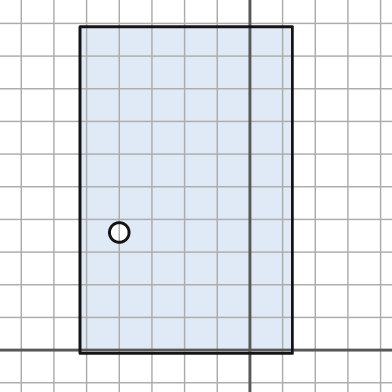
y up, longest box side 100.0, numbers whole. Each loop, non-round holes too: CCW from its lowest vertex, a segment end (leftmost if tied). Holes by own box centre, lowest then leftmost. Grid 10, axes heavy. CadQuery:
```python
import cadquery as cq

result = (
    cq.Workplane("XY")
    .moveTo(-52.0, -1.0)
    .lineTo(13.0, -1.0)
    .lineTo(13.0, 99.0)
    .lineTo(-52.0, 99.0)
    .close()
    .moveTo(-40.0, 36.0)
    .circle(3.0)
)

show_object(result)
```